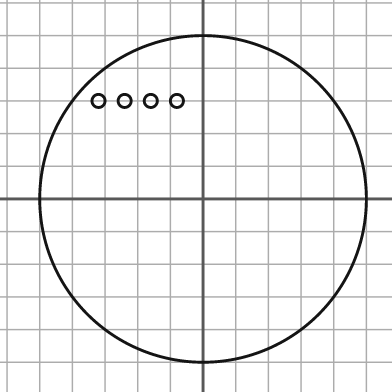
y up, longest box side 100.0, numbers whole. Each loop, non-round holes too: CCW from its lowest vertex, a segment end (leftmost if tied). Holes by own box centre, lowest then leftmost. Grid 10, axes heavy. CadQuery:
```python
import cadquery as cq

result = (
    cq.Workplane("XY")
    .moveTo(0.0, 0.0)
    .circle(50.0)
    .moveTo(-32.0, 30.0)
    .circle(2.0)
    .moveTo(-24.0, 30.0)
    .circle(2.0)
    .moveTo(-16.0, 30.0)
    .circle(2.0)
    .moveTo(-8.0, 30.0)
    .circle(2.0)
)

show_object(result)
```